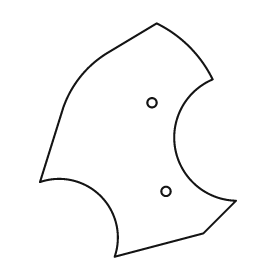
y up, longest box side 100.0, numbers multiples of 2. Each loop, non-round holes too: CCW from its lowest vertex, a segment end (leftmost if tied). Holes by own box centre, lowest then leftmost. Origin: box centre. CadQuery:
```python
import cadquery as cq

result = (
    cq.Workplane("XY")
    .moveTo(-10.0, -50.0)
    .lineTo(28.0, -40.0)
    .lineTo(42.0, -26.0)
    .threePointArc((16.0, -4.0), (32.0, 26.0))
    .threePointArc((22.0, 40.0), (8.0, 50.0))
    .lineTo(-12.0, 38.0)
    .threePointArc((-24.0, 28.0), (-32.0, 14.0))
    .lineTo(-42.0, -18.0)
    .threePointArc((-16.0, -24.0), (-10.0, -50.0))
    .close()
    .moveTo(12.0, -22.0)
    .circle(2.0)
    .moveTo(6.0, 16.0)
    .circle(2.0)
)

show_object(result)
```